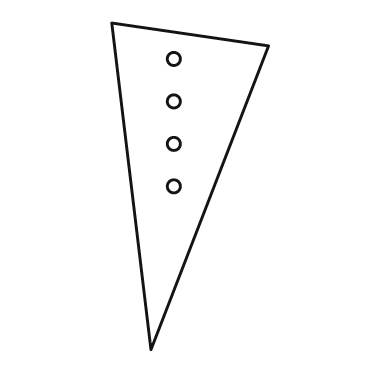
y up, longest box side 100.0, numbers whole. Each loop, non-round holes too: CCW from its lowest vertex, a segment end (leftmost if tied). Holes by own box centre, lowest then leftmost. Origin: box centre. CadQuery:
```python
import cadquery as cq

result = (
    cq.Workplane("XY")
    .moveTo(-12.0, -50.0)
    .lineTo(24.0, 43.0)
    .lineTo(-24.0, 50.0)
    .close()
    .moveTo(-5.0, 0.0)
    .circle(2.0)
    .moveTo(-5.0, 13.0)
    .circle(2.0)
    .moveTo(-5.0, 26.0)
    .circle(2.0)
    .moveTo(-5.0, 39.0)
    .circle(2.0)
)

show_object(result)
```